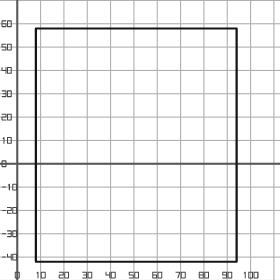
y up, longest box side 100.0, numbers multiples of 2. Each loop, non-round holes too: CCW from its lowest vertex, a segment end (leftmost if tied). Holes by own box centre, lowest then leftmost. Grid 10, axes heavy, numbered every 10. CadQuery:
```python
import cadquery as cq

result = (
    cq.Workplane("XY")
    .moveTo(8.0, -42.0)
    .lineTo(94.0, -42.0)
    .lineTo(94.0, 58.0)
    .lineTo(8.0, 58.0)
    .close()
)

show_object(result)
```